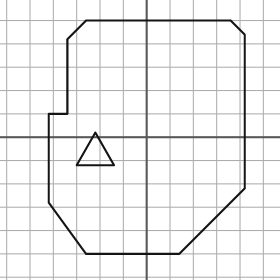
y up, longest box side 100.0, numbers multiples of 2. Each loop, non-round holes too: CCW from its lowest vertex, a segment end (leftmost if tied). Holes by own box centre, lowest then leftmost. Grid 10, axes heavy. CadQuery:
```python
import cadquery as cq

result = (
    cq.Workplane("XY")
    .moveTo(-26.0, -50.0)
    .lineTo(14.0, -50.0)
    .lineTo(42.0, -22.0)
    .lineTo(42.0, 44.0)
    .lineTo(36.0, 50.0)
    .lineTo(-26.0, 50.0)
    .lineTo(-34.0, 42.0)
    .lineTo(-34.0, 10.0)
    .lineTo(-42.0, 10.0)
    .lineTo(-42.0, -28.0)
    .close()
    .moveTo(-30.0, -12.0)
    .lineTo(-14.0, -12.0)
    .lineTo(-22.0, 2.0)
    .close()
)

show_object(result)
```